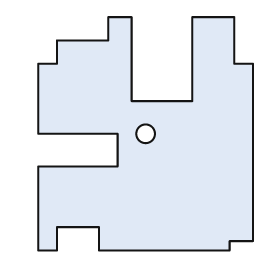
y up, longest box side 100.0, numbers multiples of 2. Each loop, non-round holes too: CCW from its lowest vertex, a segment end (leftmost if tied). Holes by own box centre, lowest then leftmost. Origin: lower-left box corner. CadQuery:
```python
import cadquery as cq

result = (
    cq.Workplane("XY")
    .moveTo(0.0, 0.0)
    .lineTo(8.0, 0.0)
    .lineTo(8.0, 10.0)
    .lineTo(26.0, 10.0)
    .lineTo(26.0, 0.0)
    .lineTo(82.0, 0.0)
    .lineTo(82.0, 4.0)
    .lineTo(92.0, 4.0)
    .lineTo(92.0, 80.0)
    .lineTo(84.0, 80.0)
    .lineTo(84.0, 100.0)
    .lineTo(66.0, 100.0)
    .lineTo(66.0, 64.0)
    .lineTo(40.0, 64.0)
    .lineTo(40.0, 100.0)
    .lineTo(30.0, 100.0)
    .lineTo(30.0, 90.0)
    .lineTo(8.0, 90.0)
    .lineTo(8.0, 80.0)
    .lineTo(0.0, 80.0)
    .lineTo(0.0, 50.0)
    .lineTo(34.0, 50.0)
    .lineTo(34.0, 36.0)
    .lineTo(0.0, 36.0)
    .close()
    .moveTo(46.0, 50.0)
    .circle(4.0)
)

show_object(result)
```